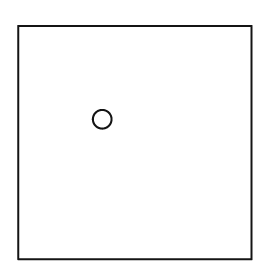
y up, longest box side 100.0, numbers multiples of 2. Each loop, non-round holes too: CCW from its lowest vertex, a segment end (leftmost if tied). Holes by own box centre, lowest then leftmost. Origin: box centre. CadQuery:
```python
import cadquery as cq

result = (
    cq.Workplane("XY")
    .moveTo(-50.0, -50.0)
    .lineTo(50.0, -50.0)
    .lineTo(50.0, 50.0)
    .lineTo(-50.0, 50.0)
    .close()
    .moveTo(-14.0, 10.0)
    .circle(4.0)
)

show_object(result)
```